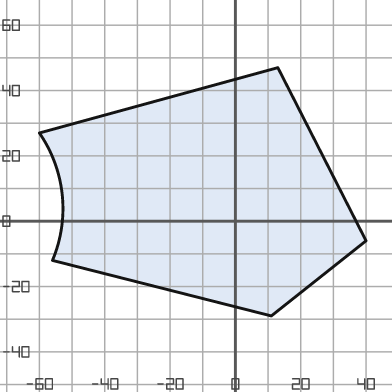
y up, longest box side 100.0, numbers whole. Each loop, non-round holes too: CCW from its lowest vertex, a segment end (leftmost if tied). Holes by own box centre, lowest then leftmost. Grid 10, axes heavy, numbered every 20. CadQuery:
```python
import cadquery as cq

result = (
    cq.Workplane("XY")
    .moveTo(11.0, -29.0)
    .lineTo(40.0, -6.0)
    .lineTo(13.0, 47.0)
    .lineTo(-60.0, 27.0)
    .threePointArc((-53.0, 8.0), (-56.0, -12.0))
    .close()
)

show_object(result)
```